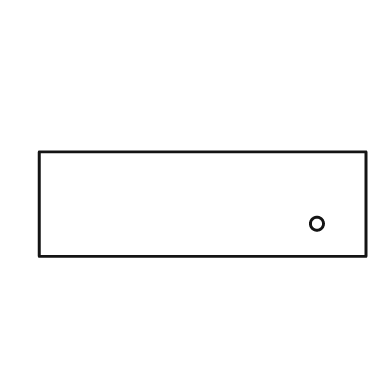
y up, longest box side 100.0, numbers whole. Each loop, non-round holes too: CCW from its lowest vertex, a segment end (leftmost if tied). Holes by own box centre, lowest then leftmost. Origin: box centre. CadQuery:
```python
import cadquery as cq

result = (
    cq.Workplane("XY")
    .moveTo(-50.0, -16.0)
    .lineTo(50.0, -16.0)
    .lineTo(50.0, 16.0)
    .lineTo(-50.0, 16.0)
    .close()
    .moveTo(35.0, -6.0)
    .circle(2.0)
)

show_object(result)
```